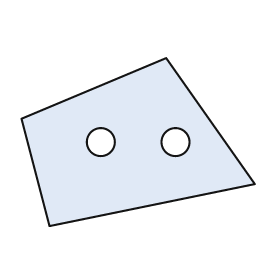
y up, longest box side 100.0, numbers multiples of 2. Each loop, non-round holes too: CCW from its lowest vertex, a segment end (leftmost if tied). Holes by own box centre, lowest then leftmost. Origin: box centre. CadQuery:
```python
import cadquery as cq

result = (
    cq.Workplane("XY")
    .moveTo(-38.0, -36.0)
    .lineTo(50.0, -18.0)
    .lineTo(12.0, 36.0)
    .lineTo(-50.0, 10.0)
    .close()
    .moveTo(-16.0, 0.0)
    .circle(6.0)
    .moveTo(16.0, 0.0)
    .circle(6.0)
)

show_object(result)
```